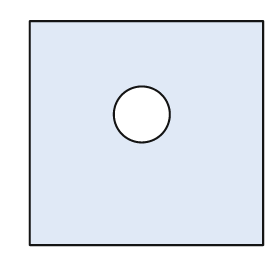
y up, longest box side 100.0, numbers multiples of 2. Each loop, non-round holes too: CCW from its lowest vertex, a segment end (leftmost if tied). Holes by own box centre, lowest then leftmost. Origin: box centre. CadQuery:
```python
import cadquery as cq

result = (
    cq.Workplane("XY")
    .moveTo(-50.0, -48.0)
    .lineTo(50.0, -48.0)
    .lineTo(50.0, 48.0)
    .lineTo(-50.0, 48.0)
    .close()
    .moveTo(-2.0, 8.0)
    .circle(12.0)
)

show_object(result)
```